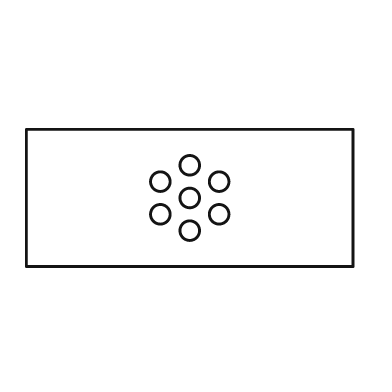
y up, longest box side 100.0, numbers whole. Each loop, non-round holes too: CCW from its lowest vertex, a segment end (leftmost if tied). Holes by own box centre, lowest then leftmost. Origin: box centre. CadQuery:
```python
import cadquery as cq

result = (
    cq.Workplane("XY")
    .moveTo(-50.0, -21.0)
    .lineTo(50.0, -21.0)
    .lineTo(50.0, 21.0)
    .lineTo(-50.0, 21.0)
    .close()
    .moveTo(0.0, -10.0)
    .circle(3.0)
    .moveTo(-9.0, -5.0)
    .circle(3.0)
    .moveTo(9.0, -5.0)
    .circle(3.0)
    .moveTo(0.0, 0.0)
    .circle(3.0)
    .moveTo(-9.0, 5.0)
    .circle(3.0)
    .moveTo(9.0, 5.0)
    .circle(3.0)
    .moveTo(0.0, 10.0)
    .circle(3.0)
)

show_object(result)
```